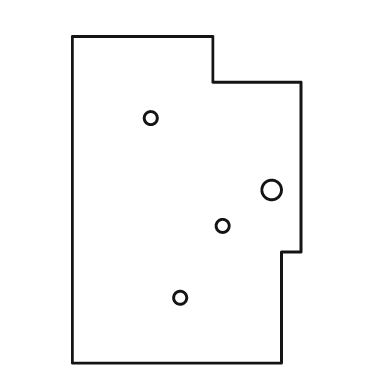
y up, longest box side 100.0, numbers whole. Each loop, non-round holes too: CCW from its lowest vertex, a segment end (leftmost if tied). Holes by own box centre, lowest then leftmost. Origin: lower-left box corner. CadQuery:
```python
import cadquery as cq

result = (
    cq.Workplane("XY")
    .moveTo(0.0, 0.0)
    .lineTo(64.0, 0.0)
    .lineTo(64.0, 34.0)
    .lineTo(70.0, 34.0)
    .lineTo(70.0, 86.0)
    .lineTo(43.0, 86.0)
    .lineTo(43.0, 100.0)
    .lineTo(0.0, 100.0)
    .close()
    .moveTo(33.0, 20.0)
    .circle(2.0)
    .moveTo(46.0, 42.0)
    .circle(2.0)
    .moveTo(61.0, 53.0)
    .circle(3.0)
    .moveTo(24.0, 75.0)
    .circle(2.0)
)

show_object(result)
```